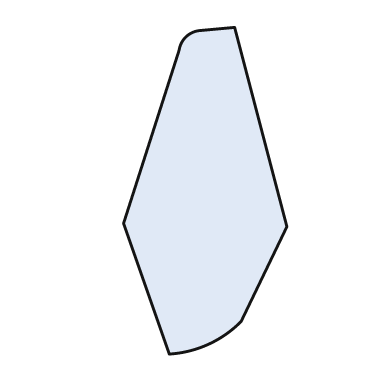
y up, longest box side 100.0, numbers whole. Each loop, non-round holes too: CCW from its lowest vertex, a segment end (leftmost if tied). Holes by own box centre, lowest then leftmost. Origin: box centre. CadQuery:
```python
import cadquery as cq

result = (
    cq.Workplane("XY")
    .moveTo(-11.0, -50.0)
    .threePointArc((1.0, -47.0), (11.0, -40.0))
    .lineTo(25.0, -11.0)
    .lineTo(9.0, 50.0)
    .lineTo(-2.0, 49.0)
    .threePointArc((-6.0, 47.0), (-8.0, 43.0))
    .lineTo(-25.0, -10.0)
    .close()
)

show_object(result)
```